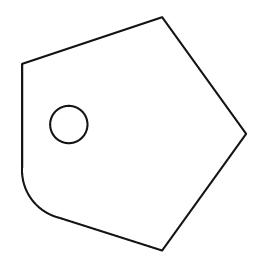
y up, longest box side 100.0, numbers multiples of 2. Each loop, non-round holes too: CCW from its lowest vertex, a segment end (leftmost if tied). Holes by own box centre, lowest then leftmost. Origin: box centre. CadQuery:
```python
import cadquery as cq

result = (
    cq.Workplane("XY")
    .moveTo(12.0, -50.0)
    .lineTo(48.0, 0.0)
    .lineTo(12.0, 50.0)
    .lineTo(-48.0, 30.0)
    .lineTo(-48.0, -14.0)
    .threePointArc((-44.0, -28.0), (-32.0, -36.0))
    .close()
    .moveTo(-28.0, 4.0)
    .circle(8.0)
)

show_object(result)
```